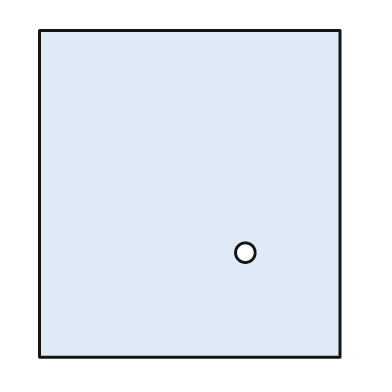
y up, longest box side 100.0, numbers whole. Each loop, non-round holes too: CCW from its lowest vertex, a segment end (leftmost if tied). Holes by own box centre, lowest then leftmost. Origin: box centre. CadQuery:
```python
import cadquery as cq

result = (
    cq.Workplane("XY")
    .moveTo(-46.0, -50.0)
    .lineTo(46.0, -50.0)
    .lineTo(46.0, 50.0)
    .lineTo(-46.0, 50.0)
    .close()
    .moveTo(17.0, -18.0)
    .circle(3.0)
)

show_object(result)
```